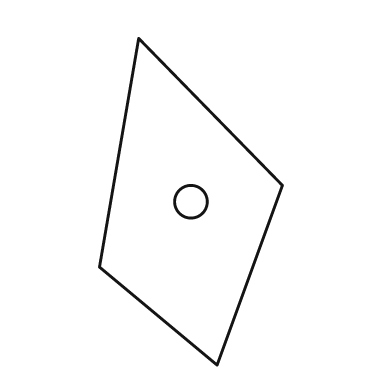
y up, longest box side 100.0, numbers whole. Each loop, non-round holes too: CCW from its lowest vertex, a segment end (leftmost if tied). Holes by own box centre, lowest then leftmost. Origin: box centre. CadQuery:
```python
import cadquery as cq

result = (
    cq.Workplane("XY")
    .moveTo(8.0, -50.0)
    .lineTo(28.0, 5.0)
    .lineTo(-16.0, 50.0)
    .lineTo(-28.0, -20.0)
    .close()
    .moveTo(0.0, 0.0)
    .circle(5.0)
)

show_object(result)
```